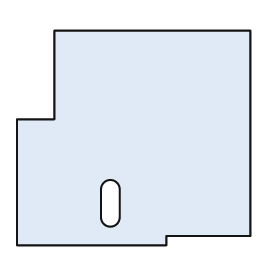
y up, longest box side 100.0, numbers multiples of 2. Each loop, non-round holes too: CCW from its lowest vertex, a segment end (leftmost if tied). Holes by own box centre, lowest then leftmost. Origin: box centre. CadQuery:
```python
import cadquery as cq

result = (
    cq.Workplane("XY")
    .moveTo(-50.0, -46.0)
    .lineTo(14.0, -46.0)
    .lineTo(14.0, -42.0)
    .lineTo(50.0, -42.0)
    .lineTo(50.0, 46.0)
    .lineTo(-34.0, 46.0)
    .lineTo(-34.0, 8.0)
    .lineTo(-50.0, 8.0)
    .close()
    .moveTo(-14.0, -34.0)
    .threePointArc((-10.0, -38.0), (-6.0, -34.0))
    .lineTo(-6.0, -22.0)
    .threePointArc((-10.0, -18.0), (-14.0, -22.0))
    .close()
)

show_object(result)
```